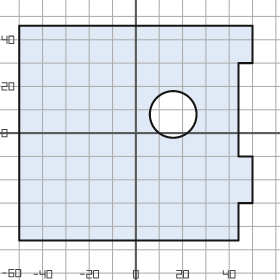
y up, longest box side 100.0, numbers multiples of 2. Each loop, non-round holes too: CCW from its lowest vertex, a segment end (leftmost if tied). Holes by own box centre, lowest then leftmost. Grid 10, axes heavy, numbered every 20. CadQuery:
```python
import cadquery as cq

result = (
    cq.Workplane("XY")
    .moveTo(-50.0, -46.0)
    .lineTo(44.0, -46.0)
    .lineTo(44.0, -30.0)
    .lineTo(50.0, -30.0)
    .lineTo(50.0, -10.0)
    .lineTo(44.0, -10.0)
    .lineTo(44.0, 30.0)
    .lineTo(50.0, 30.0)
    .lineTo(50.0, 46.0)
    .lineTo(-50.0, 46.0)
    .close()
    .moveTo(16.0, 8.0)
    .circle(10.0)
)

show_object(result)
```